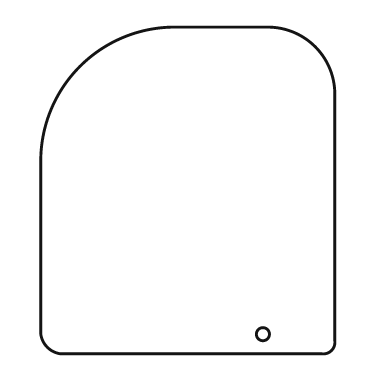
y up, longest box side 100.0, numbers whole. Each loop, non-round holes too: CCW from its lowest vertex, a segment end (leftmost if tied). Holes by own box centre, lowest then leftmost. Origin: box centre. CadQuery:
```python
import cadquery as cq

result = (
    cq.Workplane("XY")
    .moveTo(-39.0, -50.0)
    .lineTo(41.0, -50.0)
    .threePointArc((44.0, -49.0), (45.0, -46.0))
    .lineTo(45.0, 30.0)
    .threePointArc((39.0, 44.0), (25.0, 50.0))
    .lineTo(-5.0, 50.0)
    .threePointArc((-33.0, 38.0), (-45.0, 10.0))
    .lineTo(-45.0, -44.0)
    .threePointArc((-43.0, -48.0), (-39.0, -50.0))
    .close()
    .moveTo(23.0, -44.0)
    .circle(2.0)
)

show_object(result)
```